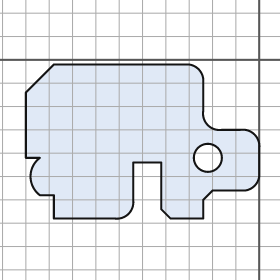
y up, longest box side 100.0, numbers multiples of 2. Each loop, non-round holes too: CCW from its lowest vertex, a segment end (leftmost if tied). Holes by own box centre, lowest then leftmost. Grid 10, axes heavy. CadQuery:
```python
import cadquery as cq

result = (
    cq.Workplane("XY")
    .moveTo(-88.0, -68.0)
    .lineTo(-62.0, -68.0)
    .threePointArc((-56.0, -66.0), (-54.0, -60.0))
    .lineTo(-54.0, -44.0)
    .lineTo(-42.0, -44.0)
    .lineTo(-42.0, -64.0)
    .lineTo(-38.0, -68.0)
    .lineTo(-24.0, -68.0)
    .lineTo(-24.0, -60.0)
    .lineTo(-20.0, -56.0)
    .lineTo(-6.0, -56.0)
    .threePointArc((-2.0, -54.0), (0.0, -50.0))
    .lineTo(0.0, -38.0)
    .threePointArc((-2.0, -32.0), (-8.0, -30.0))
    .lineTo(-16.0, -30.0)
    .threePointArc((-22.0, -28.0), (-24.0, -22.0))
    .lineTo(-24.0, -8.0)
    .threePointArc((-26.0, -4.0), (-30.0, -2.0))
    .lineTo(-88.0, -2.0)
    .lineTo(-100.0, -14.0)
    .lineTo(-100.0, -42.0)
    .lineTo(-94.0, -42.0)
    .threePointArc((-98.0, -50.0), (-94.0, -58.0))
    .lineTo(-88.0, -58.0)
    .close()
    .moveTo(-22.0, -42.0)
    .circle(6.0)
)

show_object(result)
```